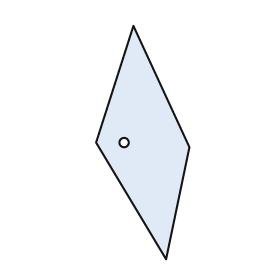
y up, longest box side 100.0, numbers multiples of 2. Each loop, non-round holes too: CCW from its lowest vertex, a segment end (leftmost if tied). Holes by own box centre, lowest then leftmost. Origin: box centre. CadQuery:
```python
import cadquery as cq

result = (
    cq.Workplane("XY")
    .moveTo(10.0, -50.0)
    .lineTo(20.0, -2.0)
    .lineTo(-4.0, 50.0)
    .lineTo(-20.0, 0.0)
    .close()
    .moveTo(-8.0, 0.0)
    .circle(2.0)
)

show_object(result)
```